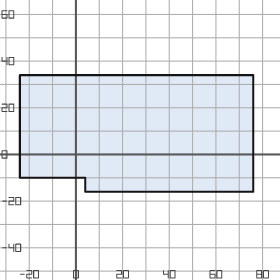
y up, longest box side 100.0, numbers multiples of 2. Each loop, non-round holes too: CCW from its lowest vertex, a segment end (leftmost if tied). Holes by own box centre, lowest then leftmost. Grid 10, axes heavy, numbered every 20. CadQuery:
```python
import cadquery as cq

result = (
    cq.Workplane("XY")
    .moveTo(4.0, -16.0)
    .lineTo(76.0, -16.0)
    .lineTo(76.0, 34.0)
    .lineTo(-24.0, 34.0)
    .lineTo(-24.0, -10.0)
    .lineTo(4.0, -10.0)
    .close()
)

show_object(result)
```